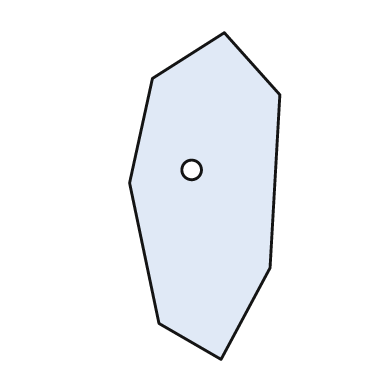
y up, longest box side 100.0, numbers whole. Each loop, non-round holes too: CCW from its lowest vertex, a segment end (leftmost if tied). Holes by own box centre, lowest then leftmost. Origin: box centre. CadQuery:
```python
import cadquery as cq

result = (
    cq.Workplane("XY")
    .moveTo(5.0, -50.0)
    .lineTo(20.0, -22.0)
    .lineTo(23.0, 31.0)
    .lineTo(6.0, 50.0)
    .lineTo(-16.0, 36.0)
    .lineTo(-23.0, 4.0)
    .lineTo(-14.0, -39.0)
    .close()
    .moveTo(-4.0, 8.0)
    .circle(3.0)
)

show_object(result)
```